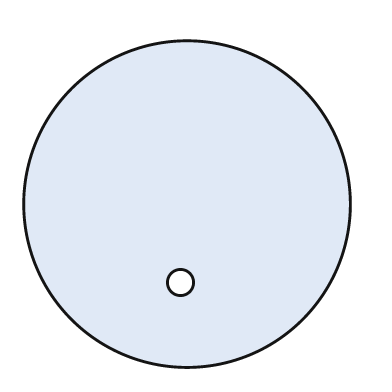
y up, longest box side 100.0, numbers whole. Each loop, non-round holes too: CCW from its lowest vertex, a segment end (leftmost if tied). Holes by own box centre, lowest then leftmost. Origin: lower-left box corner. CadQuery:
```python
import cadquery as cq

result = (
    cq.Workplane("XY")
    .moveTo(50.0, 50.0)
    .circle(50.0)
    .moveTo(48.0, 26.0)
    .circle(4.0)
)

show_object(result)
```